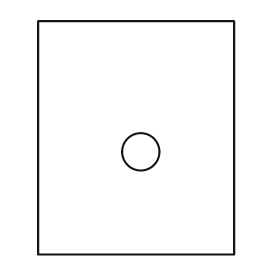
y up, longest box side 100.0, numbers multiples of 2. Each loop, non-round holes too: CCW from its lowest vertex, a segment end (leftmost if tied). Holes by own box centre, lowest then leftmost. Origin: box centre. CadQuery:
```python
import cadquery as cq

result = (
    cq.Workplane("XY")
    .moveTo(-42.0, -50.0)
    .lineTo(42.0, -50.0)
    .lineTo(42.0, 50.0)
    .lineTo(-42.0, 50.0)
    .close()
    .moveTo(2.0, -6.0)
    .circle(8.0)
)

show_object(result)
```